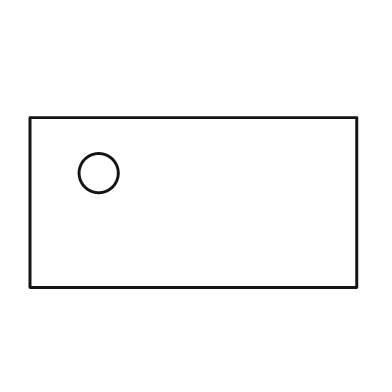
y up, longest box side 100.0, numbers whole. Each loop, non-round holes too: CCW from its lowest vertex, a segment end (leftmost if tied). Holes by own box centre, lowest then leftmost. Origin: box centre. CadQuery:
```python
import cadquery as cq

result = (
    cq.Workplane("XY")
    .moveTo(-50.0, -26.0)
    .lineTo(50.0, -26.0)
    .lineTo(50.0, 26.0)
    .lineTo(-50.0, 26.0)
    .close()
    .moveTo(-29.0, 9.0)
    .circle(6.0)
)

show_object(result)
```